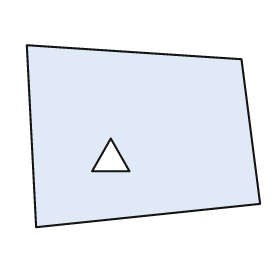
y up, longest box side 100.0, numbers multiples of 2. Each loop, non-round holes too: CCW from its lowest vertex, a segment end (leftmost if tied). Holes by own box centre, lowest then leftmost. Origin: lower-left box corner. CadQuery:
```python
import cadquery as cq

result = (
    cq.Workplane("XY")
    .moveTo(4.0, 0.0)
    .lineTo(100.0, 10.0)
    .lineTo(92.0, 72.0)
    .lineTo(0.0, 78.0)
    .close()
    .moveTo(28.0, 24.0)
    .lineTo(44.0, 24.0)
    .lineTo(36.0, 38.0)
    .close()
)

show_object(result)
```